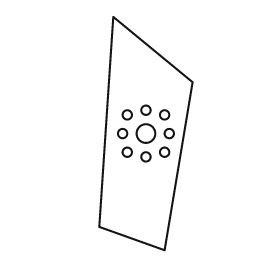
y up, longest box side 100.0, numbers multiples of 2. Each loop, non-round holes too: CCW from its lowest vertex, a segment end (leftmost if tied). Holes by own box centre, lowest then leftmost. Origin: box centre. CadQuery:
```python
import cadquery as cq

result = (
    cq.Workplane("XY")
    .moveTo(8.0, -50.0)
    .lineTo(20.0, 22.0)
    .lineTo(-14.0, 50.0)
    .lineTo(-20.0, -40.0)
    .close()
    .moveTo(0.0, -10.0)
    .circle(2.0)
    .moveTo(-8.0, -8.0)
    .circle(2.0)
    .moveTo(8.0, -8.0)
    .circle(2.0)
    .moveTo(-10.0, 0.0)
    .circle(2.0)
    .moveTo(0.0, 0.0)
    .circle(4.0)
    .moveTo(10.0, 0.0)
    .circle(2.0)
    .moveTo(-8.0, 8.0)
    .circle(2.0)
    .moveTo(8.0, 8.0)
    .circle(2.0)
    .moveTo(0.0, 10.0)
    .circle(2.0)
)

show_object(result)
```